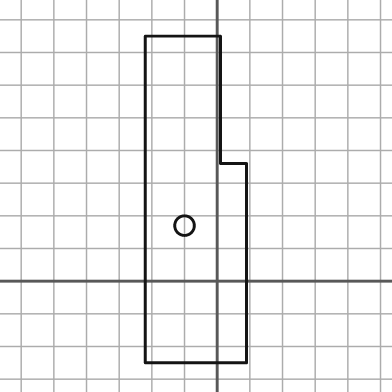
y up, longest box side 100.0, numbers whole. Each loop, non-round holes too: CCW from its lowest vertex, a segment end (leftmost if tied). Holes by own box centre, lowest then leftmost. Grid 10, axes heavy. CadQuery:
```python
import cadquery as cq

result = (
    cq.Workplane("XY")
    .moveTo(-22.0, -25.0)
    .lineTo(9.0, -25.0)
    .lineTo(9.0, 36.0)
    .lineTo(1.0, 36.0)
    .lineTo(1.0, 75.0)
    .lineTo(-22.0, 75.0)
    .close()
    .moveTo(-10.0, 17.0)
    .circle(3.0)
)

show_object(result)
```